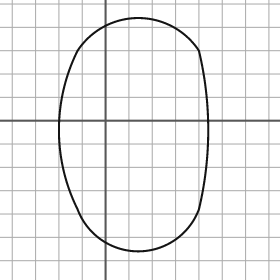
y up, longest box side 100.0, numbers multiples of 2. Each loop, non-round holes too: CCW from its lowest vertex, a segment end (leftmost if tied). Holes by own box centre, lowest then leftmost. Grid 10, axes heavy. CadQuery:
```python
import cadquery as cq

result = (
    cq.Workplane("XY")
    .moveTo(-12.0, -38.0)
    .threePointArc((14.0, -56.0), (40.0, -38.0))
    .threePointArc((44.0, -4.0), (40.0, 30.0))
    .threePointArc((14.0, 44.0), (-12.0, 30.0))
    .threePointArc((-20.0, -4.0), (-12.0, -38.0))
    .close()
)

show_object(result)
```